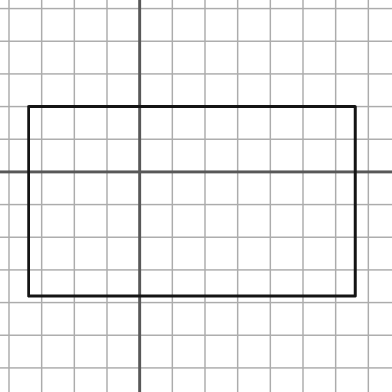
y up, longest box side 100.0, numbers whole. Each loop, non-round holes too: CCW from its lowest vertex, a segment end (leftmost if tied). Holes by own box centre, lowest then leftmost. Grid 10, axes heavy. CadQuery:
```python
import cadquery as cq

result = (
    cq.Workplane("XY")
    .moveTo(-34.0, -38.0)
    .lineTo(66.0, -38.0)
    .lineTo(66.0, 20.0)
    .lineTo(-34.0, 20.0)
    .close()
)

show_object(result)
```